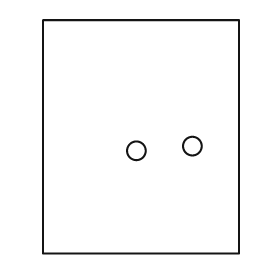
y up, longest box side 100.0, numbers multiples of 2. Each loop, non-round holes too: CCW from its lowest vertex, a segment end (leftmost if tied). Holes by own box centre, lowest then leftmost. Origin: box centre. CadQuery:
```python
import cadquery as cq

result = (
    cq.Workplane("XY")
    .moveTo(-42.0, -50.0)
    .lineTo(42.0, -50.0)
    .lineTo(42.0, 50.0)
    .lineTo(-42.0, 50.0)
    .close()
    .moveTo(-2.0, -6.0)
    .circle(4.0)
    .moveTo(22.0, -4.0)
    .circle(4.0)
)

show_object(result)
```